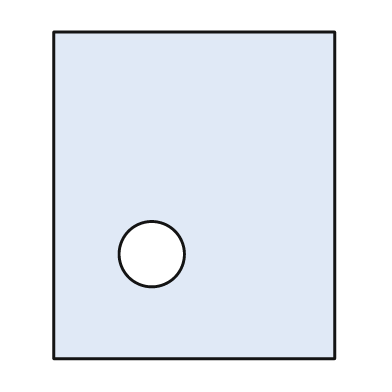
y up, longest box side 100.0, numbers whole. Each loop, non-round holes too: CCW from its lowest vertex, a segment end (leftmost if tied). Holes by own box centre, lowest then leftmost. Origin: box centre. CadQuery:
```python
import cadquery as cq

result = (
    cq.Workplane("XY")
    .moveTo(-43.0, -50.0)
    .lineTo(43.0, -50.0)
    .lineTo(43.0, 50.0)
    .lineTo(-43.0, 50.0)
    .close()
    .moveTo(-13.0, -18.0)
    .circle(10.0)
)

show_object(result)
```